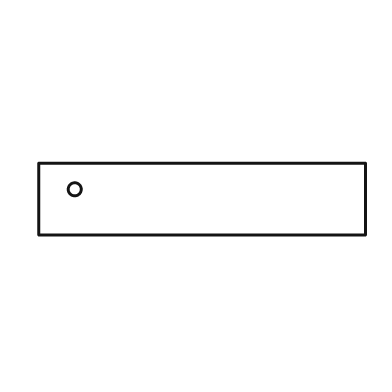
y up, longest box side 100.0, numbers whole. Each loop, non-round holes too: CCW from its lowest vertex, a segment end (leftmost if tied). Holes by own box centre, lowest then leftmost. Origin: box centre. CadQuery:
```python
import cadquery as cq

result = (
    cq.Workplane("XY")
    .moveTo(-50.0, -11.0)
    .lineTo(50.0, -11.0)
    .lineTo(50.0, 11.0)
    .lineTo(-50.0, 11.0)
    .close()
    .moveTo(-39.0, 3.0)
    .circle(2.0)
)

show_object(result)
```